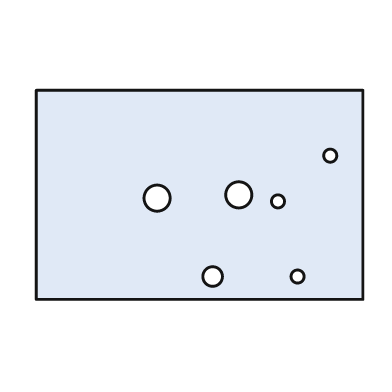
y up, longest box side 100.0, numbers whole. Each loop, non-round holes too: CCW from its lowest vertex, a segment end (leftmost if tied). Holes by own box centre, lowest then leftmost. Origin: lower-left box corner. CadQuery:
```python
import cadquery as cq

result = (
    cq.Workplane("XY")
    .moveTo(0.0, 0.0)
    .lineTo(100.0, 0.0)
    .lineTo(100.0, 64.0)
    .lineTo(0.0, 64.0)
    .close()
    .moveTo(54.0, 7.0)
    .circle(3.0)
    .moveTo(80.0, 7.0)
    .circle(2.0)
    .moveTo(74.0, 30.0)
    .circle(2.0)
    .moveTo(37.0, 31.0)
    .circle(4.0)
    .moveTo(62.0, 32.0)
    .circle(4.0)
    .moveTo(90.0, 44.0)
    .circle(2.0)
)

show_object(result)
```